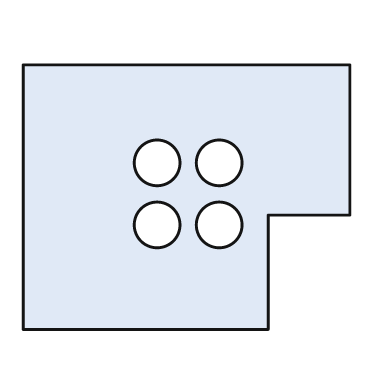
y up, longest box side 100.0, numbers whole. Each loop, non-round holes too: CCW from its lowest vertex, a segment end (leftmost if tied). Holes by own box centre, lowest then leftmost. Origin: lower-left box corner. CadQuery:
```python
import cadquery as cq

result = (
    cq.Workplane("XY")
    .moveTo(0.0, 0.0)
    .lineTo(75.0, 0.0)
    .lineTo(75.0, 35.0)
    .lineTo(100.0, 35.0)
    .lineTo(100.0, 81.0)
    .lineTo(0.0, 81.0)
    .close()
    .moveTo(41.0, 32.0)
    .circle(7.0)
    .moveTo(60.0, 32.0)
    .circle(7.0)
    .moveTo(41.0, 51.0)
    .circle(7.0)
    .moveTo(60.0, 51.0)
    .circle(7.0)
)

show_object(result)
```